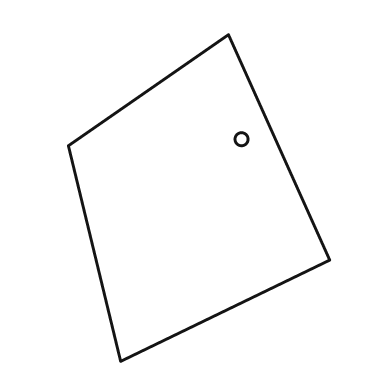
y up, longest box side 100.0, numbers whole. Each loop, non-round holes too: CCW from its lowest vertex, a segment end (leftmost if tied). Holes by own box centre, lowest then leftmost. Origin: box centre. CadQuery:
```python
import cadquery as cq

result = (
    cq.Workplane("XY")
    .moveTo(-24.0, -50.0)
    .lineTo(40.0, -19.0)
    .lineTo(9.0, 50.0)
    .lineTo(-40.0, 16.0)
    .close()
    .moveTo(13.0, 18.0)
    .circle(2.0)
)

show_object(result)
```